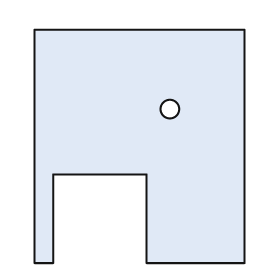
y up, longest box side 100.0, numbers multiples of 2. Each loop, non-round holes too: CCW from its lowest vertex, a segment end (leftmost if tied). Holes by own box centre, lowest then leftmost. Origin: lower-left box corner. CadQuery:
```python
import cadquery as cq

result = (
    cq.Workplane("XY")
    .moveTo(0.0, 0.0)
    .lineTo(8.0, 0.0)
    .lineTo(8.0, 38.0)
    .lineTo(48.0, 38.0)
    .lineTo(48.0, 0.0)
    .lineTo(90.0, 0.0)
    .lineTo(90.0, 100.0)
    .lineTo(0.0, 100.0)
    .close()
    .moveTo(58.0, 66.0)
    .circle(4.0)
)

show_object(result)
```